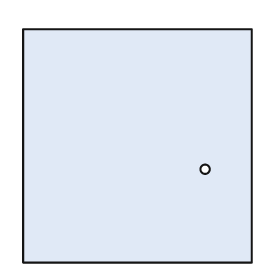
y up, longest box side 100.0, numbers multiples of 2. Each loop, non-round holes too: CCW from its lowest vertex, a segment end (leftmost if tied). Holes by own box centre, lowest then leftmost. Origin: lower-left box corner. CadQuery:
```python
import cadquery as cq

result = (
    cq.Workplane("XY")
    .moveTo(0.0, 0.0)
    .lineTo(98.0, 0.0)
    .lineTo(98.0, 100.0)
    .lineTo(0.0, 100.0)
    .close()
    .moveTo(78.0, 40.0)
    .circle(2.0)
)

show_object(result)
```